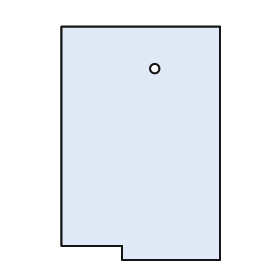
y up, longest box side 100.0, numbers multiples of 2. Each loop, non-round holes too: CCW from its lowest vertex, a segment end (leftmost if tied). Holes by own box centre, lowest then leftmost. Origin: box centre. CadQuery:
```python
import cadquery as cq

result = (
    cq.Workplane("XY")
    .moveTo(-8.0, -50.0)
    .lineTo(34.0, -50.0)
    .lineTo(34.0, 50.0)
    .lineTo(-34.0, 50.0)
    .lineTo(-34.0, -44.0)
    .lineTo(-8.0, -44.0)
    .close()
    .moveTo(6.0, 32.0)
    .circle(2.0)
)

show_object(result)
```